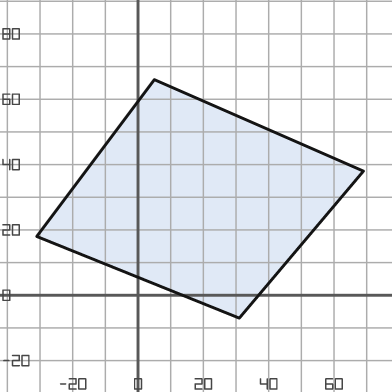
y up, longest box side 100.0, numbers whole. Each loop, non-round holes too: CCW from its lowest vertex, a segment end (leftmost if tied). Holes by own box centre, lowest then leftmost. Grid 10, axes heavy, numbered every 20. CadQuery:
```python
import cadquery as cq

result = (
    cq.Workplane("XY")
    .moveTo(31.0, -7.0)
    .lineTo(69.0, 38.0)
    .lineTo(5.0, 66.0)
    .lineTo(-31.0, 18.0)
    .close()
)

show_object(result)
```